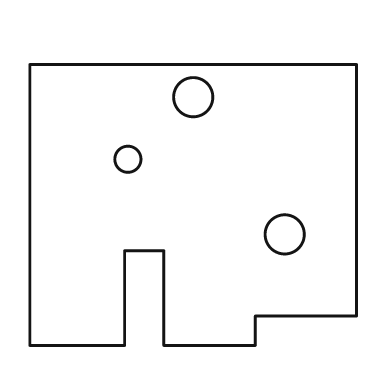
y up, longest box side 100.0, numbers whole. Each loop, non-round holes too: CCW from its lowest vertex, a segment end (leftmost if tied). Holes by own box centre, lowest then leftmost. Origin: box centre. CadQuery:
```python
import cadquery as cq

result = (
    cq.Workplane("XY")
    .moveTo(-50.0, -43.0)
    .lineTo(-21.0, -43.0)
    .lineTo(-21.0, -14.0)
    .lineTo(-9.0, -14.0)
    .lineTo(-9.0, -43.0)
    .lineTo(19.0, -43.0)
    .lineTo(19.0, -34.0)
    .lineTo(50.0, -34.0)
    .lineTo(50.0, 43.0)
    .lineTo(-50.0, 43.0)
    .close()
    .moveTo(28.0, -9.0)
    .circle(6.0)
    .moveTo(-20.0, 14.0)
    .circle(4.0)
    .moveTo(0.0, 33.0)
    .circle(6.0)
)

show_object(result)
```